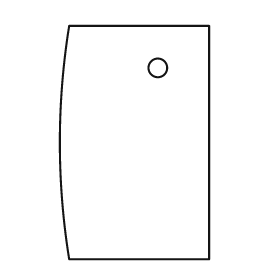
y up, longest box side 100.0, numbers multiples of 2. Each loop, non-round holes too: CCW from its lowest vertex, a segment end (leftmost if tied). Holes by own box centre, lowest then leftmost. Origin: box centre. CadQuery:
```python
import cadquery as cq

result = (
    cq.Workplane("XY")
    .moveTo(-28.0, -50.0)
    .lineTo(32.0, -50.0)
    .lineTo(32.0, 50.0)
    .lineTo(-28.0, 50.0)
    .threePointArc((-32.0, 0.0), (-28.0, -50.0))
    .close()
    .moveTo(10.0, 32.0)
    .circle(4.0)
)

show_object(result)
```